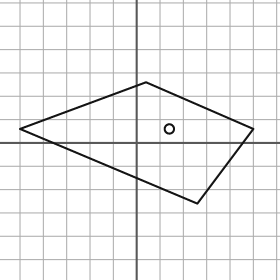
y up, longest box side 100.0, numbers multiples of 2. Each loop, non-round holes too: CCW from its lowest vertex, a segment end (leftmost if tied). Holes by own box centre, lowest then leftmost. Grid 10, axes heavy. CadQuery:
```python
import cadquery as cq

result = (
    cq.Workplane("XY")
    .moveTo(26.0, -26.0)
    .lineTo(50.0, 6.0)
    .lineTo(4.0, 26.0)
    .lineTo(-50.0, 6.0)
    .close()
    .moveTo(14.0, 6.0)
    .circle(2.0)
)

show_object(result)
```